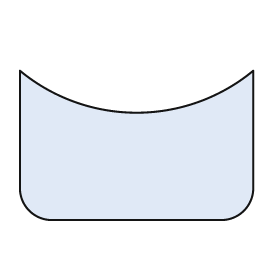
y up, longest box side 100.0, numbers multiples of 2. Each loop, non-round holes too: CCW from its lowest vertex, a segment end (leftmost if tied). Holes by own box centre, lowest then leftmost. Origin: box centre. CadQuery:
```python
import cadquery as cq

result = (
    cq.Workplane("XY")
    .moveTo(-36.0, -32.0)
    .lineTo(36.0, -32.0)
    .threePointArc((46.0, -28.0), (50.0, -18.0))
    .lineTo(50.0, 32.0)
    .threePointArc((0.0, 14.0), (-50.0, 32.0))
    .lineTo(-50.0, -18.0)
    .threePointArc((-46.0, -28.0), (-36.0, -32.0))
    .close()
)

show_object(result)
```